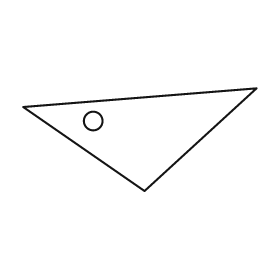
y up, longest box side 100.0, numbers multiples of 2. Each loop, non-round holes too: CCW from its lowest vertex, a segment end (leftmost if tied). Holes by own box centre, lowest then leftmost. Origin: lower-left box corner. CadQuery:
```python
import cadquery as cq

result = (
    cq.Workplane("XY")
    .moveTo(52.0, 0.0)
    .lineTo(100.0, 44.0)
    .lineTo(0.0, 36.0)
    .close()
    .moveTo(30.0, 30.0)
    .circle(4.0)
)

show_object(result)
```